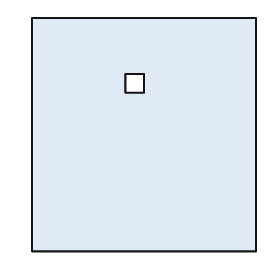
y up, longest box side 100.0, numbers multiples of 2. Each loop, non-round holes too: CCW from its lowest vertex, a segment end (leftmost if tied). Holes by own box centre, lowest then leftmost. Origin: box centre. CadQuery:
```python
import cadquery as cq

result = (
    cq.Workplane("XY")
    .moveTo(-48.0, -50.0)
    .lineTo(48.0, -50.0)
    .lineTo(48.0, 50.0)
    .lineTo(-48.0, 50.0)
    .close()
    .moveTo(-8.0, 18.0)
    .lineTo(0.0, 18.0)
    .lineTo(0.0, 26.0)
    .lineTo(-8.0, 26.0)
    .close()
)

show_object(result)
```